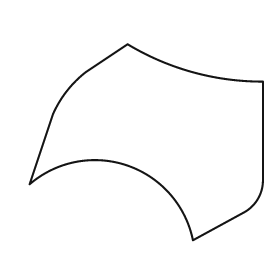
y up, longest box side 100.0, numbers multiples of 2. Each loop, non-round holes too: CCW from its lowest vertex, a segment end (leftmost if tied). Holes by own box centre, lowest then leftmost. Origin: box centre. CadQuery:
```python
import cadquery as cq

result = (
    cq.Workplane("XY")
    .moveTo(20.0, -42.0)
    .lineTo(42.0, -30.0)
    .threePointArc((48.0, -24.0), (50.0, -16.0))
    .lineTo(50.0, 26.0)
    .threePointArc((20.0, 30.0), (-8.0, 42.0))
    .lineTo(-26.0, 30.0)
    .threePointArc((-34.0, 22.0), (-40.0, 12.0))
    .lineTo(-50.0, -18.0)
    .threePointArc((-8.0, -10.0), (20.0, -42.0))
    .close()
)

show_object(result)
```